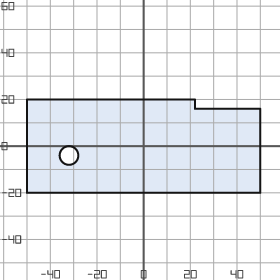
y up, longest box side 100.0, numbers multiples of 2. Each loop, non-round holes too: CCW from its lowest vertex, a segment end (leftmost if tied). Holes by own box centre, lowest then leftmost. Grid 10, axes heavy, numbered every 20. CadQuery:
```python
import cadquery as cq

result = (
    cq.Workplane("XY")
    .moveTo(-50.0, -20.0)
    .lineTo(50.0, -20.0)
    .lineTo(50.0, 16.0)
    .lineTo(22.0, 16.0)
    .lineTo(22.0, 20.0)
    .lineTo(-50.0, 20.0)
    .close()
    .moveTo(-32.0, -4.0)
    .circle(4.0)
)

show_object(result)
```